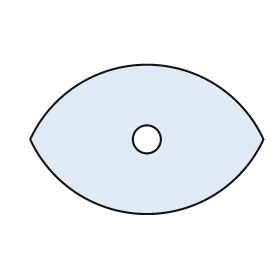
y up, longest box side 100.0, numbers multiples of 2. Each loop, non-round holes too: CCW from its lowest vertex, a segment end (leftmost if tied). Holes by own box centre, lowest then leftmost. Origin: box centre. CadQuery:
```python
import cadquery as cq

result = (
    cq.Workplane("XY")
    .moveTo(-50.0, 0.0)
    .threePointArc((0.0, -32.0), (50.0, 0.0))
    .threePointArc((0.0, 32.0), (-50.0, 0.0))
    .close()
    .moveTo(0.0, 0.0)
    .circle(6.0)
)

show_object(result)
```